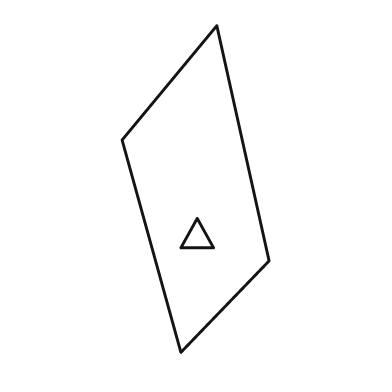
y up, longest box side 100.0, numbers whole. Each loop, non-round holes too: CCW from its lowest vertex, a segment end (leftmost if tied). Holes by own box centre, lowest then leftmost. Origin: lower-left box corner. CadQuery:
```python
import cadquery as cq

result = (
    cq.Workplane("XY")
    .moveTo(18.0, 0.0)
    .lineTo(45.0, 28.0)
    .lineTo(29.0, 100.0)
    .lineTo(0.0, 65.0)
    .close()
    .moveTo(18.0, 32.0)
    .lineTo(28.0, 32.0)
    .lineTo(23.0, 41.0)
    .close()
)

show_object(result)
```